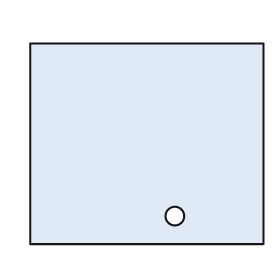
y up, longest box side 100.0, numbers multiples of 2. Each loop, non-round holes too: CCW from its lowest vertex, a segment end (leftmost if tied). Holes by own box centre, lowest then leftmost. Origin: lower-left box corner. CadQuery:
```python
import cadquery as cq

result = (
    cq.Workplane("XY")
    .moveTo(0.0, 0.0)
    .lineTo(100.0, 0.0)
    .lineTo(100.0, 86.0)
    .lineTo(0.0, 86.0)
    .close()
    .moveTo(62.0, 12.0)
    .circle(4.0)
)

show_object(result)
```